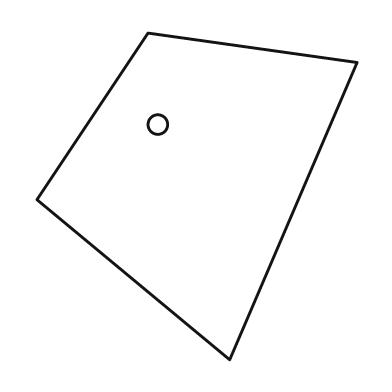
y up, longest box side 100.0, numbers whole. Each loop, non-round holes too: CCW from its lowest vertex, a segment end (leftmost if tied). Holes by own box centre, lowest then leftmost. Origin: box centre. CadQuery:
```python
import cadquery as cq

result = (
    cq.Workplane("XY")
    .moveTo(10.0, -50.0)
    .lineTo(49.0, 41.0)
    .lineTo(-15.0, 50.0)
    .lineTo(-49.0, -1.0)
    .close()
    .moveTo(-12.0, 22.0)
    .circle(3.0)
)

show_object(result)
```